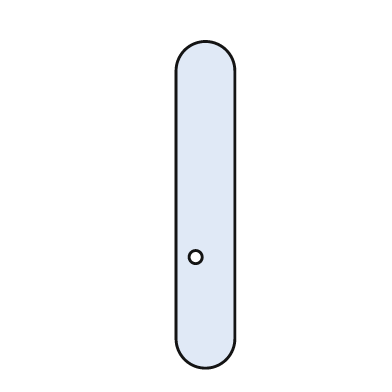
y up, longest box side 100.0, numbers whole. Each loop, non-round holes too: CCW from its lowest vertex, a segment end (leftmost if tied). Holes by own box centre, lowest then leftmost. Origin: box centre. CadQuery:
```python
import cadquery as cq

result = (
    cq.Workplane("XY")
    .moveTo(-9.0, -41.0)
    .threePointArc((0.0, -50.0), (9.0, -41.0))
    .lineTo(9.0, 41.0)
    .threePointArc((0.0, 50.0), (-9.0, 41.0))
    .close()
    .moveTo(-3.0, -16.0)
    .circle(2.0)
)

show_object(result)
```